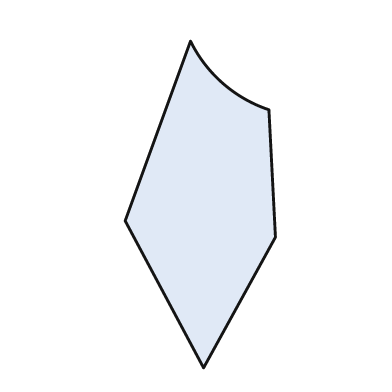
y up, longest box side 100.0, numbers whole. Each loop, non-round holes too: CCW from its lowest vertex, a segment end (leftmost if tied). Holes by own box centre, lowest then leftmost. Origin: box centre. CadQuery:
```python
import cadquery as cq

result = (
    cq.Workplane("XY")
    .moveTo(1.0, -50.0)
    .lineTo(23.0, -10.0)
    .lineTo(21.0, 29.0)
    .threePointArc((7.0, 37.0), (-3.0, 50.0))
    .lineTo(-23.0, -5.0)
    .close()
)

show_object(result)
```